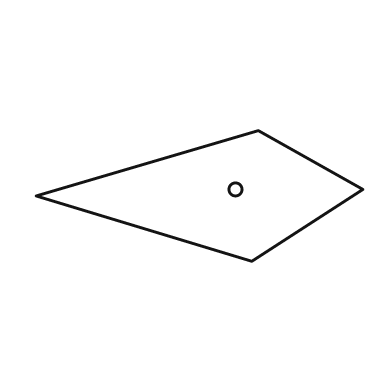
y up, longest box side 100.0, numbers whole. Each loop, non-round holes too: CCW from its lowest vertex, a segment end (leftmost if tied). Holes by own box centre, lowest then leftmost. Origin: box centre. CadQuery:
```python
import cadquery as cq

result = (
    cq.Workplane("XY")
    .moveTo(16.0, -20.0)
    .lineTo(50.0, 2.0)
    .lineTo(18.0, 20.0)
    .lineTo(-50.0, 0.0)
    .close()
    .moveTo(11.0, 2.0)
    .circle(2.0)
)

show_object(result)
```